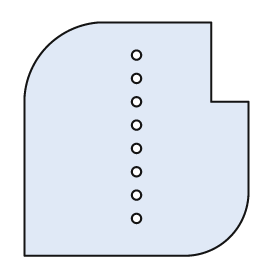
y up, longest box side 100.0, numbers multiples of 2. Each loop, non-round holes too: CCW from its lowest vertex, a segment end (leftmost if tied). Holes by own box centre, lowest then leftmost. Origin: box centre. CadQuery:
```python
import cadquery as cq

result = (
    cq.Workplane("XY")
    .moveTo(-48.0, -50.0)
    .lineTo(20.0, -50.0)
    .threePointArc((40.0, -42.0), (48.0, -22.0))
    .lineTo(48.0, 16.0)
    .lineTo(32.0, 16.0)
    .lineTo(32.0, 50.0)
    .lineTo(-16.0, 50.0)
    .threePointArc((-38.0, 40.0), (-48.0, 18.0))
    .close()
    .moveTo(0.0, -34.0)
    .circle(2.0)
    .moveTo(0.0, -24.0)
    .circle(2.0)
    .moveTo(0.0, -14.0)
    .circle(2.0)
    .moveTo(0.0, -4.0)
    .circle(2.0)
    .moveTo(0.0, 6.0)
    .circle(2.0)
    .moveTo(0.0, 16.0)
    .circle(2.0)
    .moveTo(0.0, 26.0)
    .circle(2.0)
    .moveTo(0.0, 36.0)
    .circle(2.0)
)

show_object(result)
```